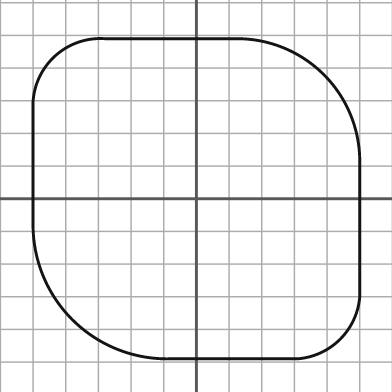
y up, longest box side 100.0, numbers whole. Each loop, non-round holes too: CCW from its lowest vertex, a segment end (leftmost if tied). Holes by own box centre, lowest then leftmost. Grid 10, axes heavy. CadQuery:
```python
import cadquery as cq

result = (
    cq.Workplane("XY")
    .moveTo(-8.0, -49.0)
    .lineTo(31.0, -49.0)
    .threePointArc((44.0, -43.0), (50.0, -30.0))
    .lineTo(50.0, 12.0)
    .threePointArc((39.0, 38.0), (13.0, 49.0))
    .lineTo(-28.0, 49.0)
    .threePointArc((-44.0, 43.0), (-50.0, 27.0))
    .lineTo(-50.0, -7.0)
    .threePointArc((-38.0, -37.0), (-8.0, -49.0))
    .close()
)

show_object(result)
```